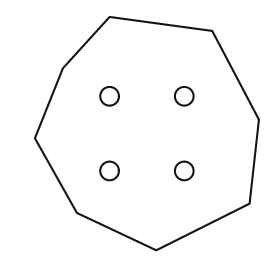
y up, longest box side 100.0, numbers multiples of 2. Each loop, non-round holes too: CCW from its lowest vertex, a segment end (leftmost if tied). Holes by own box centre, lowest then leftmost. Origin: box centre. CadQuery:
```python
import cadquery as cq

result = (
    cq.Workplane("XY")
    .moveTo(4.0, -50.0)
    .lineTo(44.0, -30.0)
    .lineTo(48.0, 6.0)
    .lineTo(28.0, 44.0)
    .lineTo(-16.0, 50.0)
    .lineTo(-36.0, 28.0)
    .lineTo(-48.0, -2.0)
    .lineTo(-30.0, -34.0)
    .close()
    .moveTo(-16.0, -16.0)
    .circle(4.0)
    .moveTo(16.0, -16.0)
    .circle(4.0)
    .moveTo(-16.0, 16.0)
    .circle(4.0)
    .moveTo(16.0, 16.0)
    .circle(4.0)
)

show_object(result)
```